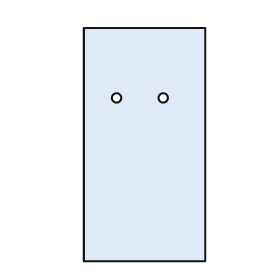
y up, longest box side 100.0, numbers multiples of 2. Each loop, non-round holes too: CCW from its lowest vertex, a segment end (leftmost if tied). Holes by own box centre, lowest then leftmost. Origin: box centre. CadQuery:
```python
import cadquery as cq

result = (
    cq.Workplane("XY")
    .moveTo(-26.0, -50.0)
    .lineTo(26.0, -50.0)
    .lineTo(26.0, 50.0)
    .lineTo(-26.0, 50.0)
    .close()
    .moveTo(-12.0, 20.0)
    .circle(2.0)
    .moveTo(8.0, 20.0)
    .circle(2.0)
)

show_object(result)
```